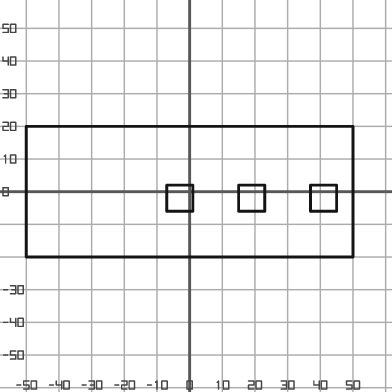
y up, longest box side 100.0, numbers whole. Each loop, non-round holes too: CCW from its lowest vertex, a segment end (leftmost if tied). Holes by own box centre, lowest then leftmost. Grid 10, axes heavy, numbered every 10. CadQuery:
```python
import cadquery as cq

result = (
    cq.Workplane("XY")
    .moveTo(-50.0, -20.0)
    .lineTo(50.0, -20.0)
    .lineTo(50.0, 20.0)
    .lineTo(-50.0, 20.0)
    .close()
    .moveTo(-7.0, -6.0)
    .lineTo(1.0, -6.0)
    .lineTo(1.0, 2.0)
    .lineTo(-7.0, 2.0)
    .close()
    .moveTo(15.0, -6.0)
    .lineTo(23.0, -6.0)
    .lineTo(23.0, 2.0)
    .lineTo(15.0, 2.0)
    .close()
    .moveTo(37.0, -6.0)
    .lineTo(45.0, -6.0)
    .lineTo(45.0, 2.0)
    .lineTo(37.0, 2.0)
    .close()
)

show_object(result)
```